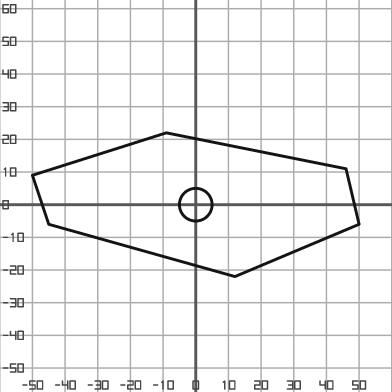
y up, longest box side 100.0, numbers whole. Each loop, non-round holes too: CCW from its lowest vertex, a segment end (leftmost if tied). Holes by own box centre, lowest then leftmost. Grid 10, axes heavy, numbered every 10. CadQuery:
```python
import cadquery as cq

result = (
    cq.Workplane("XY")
    .moveTo(12.0, -22.0)
    .lineTo(50.0, -6.0)
    .lineTo(46.0, 11.0)
    .lineTo(-9.0, 22.0)
    .lineTo(-50.0, 9.0)
    .lineTo(-45.0, -6.0)
    .close()
    .moveTo(0.0, 0.0)
    .circle(5.0)
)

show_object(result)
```